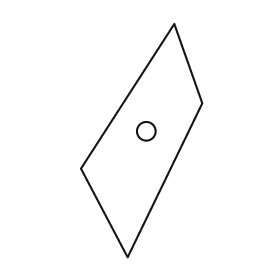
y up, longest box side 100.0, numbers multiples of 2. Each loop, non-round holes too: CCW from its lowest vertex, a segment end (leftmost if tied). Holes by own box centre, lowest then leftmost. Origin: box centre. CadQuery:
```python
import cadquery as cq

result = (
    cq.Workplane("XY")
    .moveTo(-6.0, -50.0)
    .lineTo(26.0, 16.0)
    .lineTo(14.0, 50.0)
    .lineTo(-26.0, -12.0)
    .close()
    .moveTo(2.0, 4.0)
    .circle(4.0)
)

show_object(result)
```